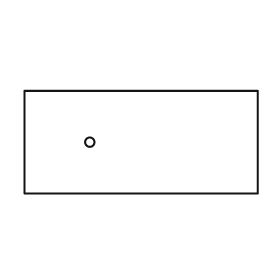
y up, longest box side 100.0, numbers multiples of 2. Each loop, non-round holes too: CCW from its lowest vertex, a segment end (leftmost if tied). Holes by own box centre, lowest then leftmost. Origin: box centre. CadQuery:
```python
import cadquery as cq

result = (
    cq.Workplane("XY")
    .moveTo(-50.0, -22.0)
    .lineTo(50.0, -22.0)
    .lineTo(50.0, 22.0)
    .lineTo(-50.0, 22.0)
    .close()
    .moveTo(-22.0, 0.0)
    .circle(2.0)
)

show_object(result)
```